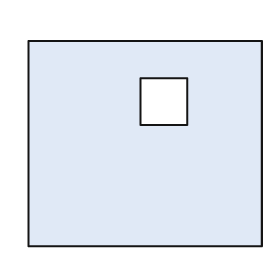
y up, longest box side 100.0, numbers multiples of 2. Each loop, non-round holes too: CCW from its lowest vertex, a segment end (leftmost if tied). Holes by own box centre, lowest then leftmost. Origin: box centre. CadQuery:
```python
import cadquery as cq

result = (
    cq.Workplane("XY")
    .moveTo(-50.0, -44.0)
    .lineTo(50.0, -44.0)
    .lineTo(50.0, 44.0)
    .lineTo(-50.0, 44.0)
    .close()
    .moveTo(-2.0, 8.0)
    .lineTo(18.0, 8.0)
    .lineTo(18.0, 28.0)
    .lineTo(-2.0, 28.0)
    .close()
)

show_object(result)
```